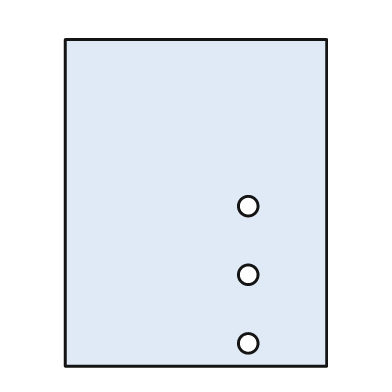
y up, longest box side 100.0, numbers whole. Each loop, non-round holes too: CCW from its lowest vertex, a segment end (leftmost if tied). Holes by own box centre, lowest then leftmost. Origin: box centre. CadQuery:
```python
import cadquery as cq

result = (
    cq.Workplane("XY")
    .moveTo(-40.0, -50.0)
    .lineTo(40.0, -50.0)
    .lineTo(40.0, 50.0)
    .lineTo(-40.0, 50.0)
    .close()
    .moveTo(16.0, -43.0)
    .circle(3.0)
    .moveTo(16.0, -22.0)
    .circle(3.0)
    .moveTo(16.0, -1.0)
    .circle(3.0)
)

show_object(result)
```